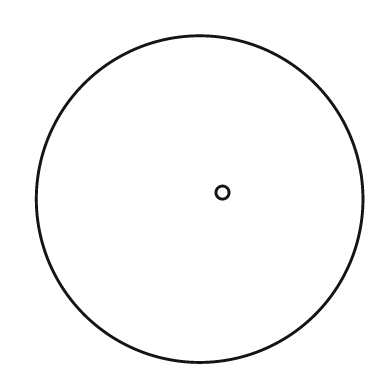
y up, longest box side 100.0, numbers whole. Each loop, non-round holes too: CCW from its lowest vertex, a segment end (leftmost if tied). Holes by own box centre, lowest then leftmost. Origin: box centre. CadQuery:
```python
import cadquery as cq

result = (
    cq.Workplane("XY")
    .moveTo(0.0, 0.0)
    .circle(50.0)
    .moveTo(7.0, 2.0)
    .circle(2.0)
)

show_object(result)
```